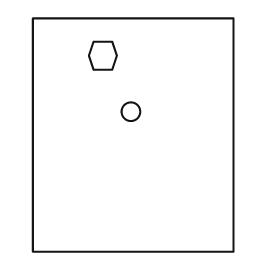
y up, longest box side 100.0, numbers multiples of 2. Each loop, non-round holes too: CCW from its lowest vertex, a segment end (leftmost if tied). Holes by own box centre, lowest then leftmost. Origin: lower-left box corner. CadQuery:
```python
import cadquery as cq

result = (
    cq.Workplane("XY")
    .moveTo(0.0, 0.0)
    .lineTo(86.0, 0.0)
    .lineTo(86.0, 100.0)
    .lineTo(0.0, 100.0)
    .close()
    .moveTo(42.0, 60.0)
    .circle(4.0)
    .moveTo(26.0, 78.0)
    .lineTo(34.0, 78.0)
    .lineTo(36.0, 84.0)
    .lineTo(34.0, 90.0)
    .lineTo(26.0, 90.0)
    .lineTo(24.0, 84.0)
    .close()
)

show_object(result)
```